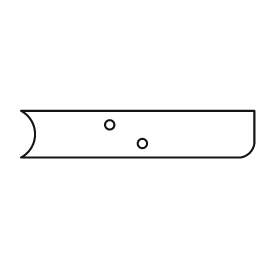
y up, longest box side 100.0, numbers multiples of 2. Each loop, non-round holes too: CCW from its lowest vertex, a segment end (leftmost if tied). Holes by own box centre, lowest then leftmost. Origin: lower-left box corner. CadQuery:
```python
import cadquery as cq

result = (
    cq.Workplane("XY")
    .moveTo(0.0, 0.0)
    .lineTo(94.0, 0.0)
    .threePointArc((98.0, 2.0), (100.0, 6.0))
    .lineTo(100.0, 20.0)
    .lineTo(0.0, 20.0)
    .threePointArc((6.0, 10.0), (0.0, 0.0))
    .close()
    .moveTo(52.0, 6.0)
    .circle(2.0)
    .moveTo(38.0, 14.0)
    .circle(2.0)
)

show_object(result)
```